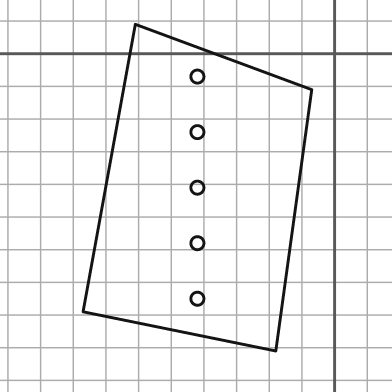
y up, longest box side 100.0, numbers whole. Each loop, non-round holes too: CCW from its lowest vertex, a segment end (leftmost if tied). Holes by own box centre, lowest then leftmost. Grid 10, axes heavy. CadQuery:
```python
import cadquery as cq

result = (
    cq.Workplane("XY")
    .moveTo(-18.0, -91.0)
    .lineTo(-7.0, -11.0)
    .lineTo(-61.0, 9.0)
    .lineTo(-77.0, -79.0)
    .close()
    .moveTo(-42.0, -75.0)
    .circle(2.0)
    .moveTo(-42.0, -58.0)
    .circle(2.0)
    .moveTo(-42.0, -41.0)
    .circle(2.0)
    .moveTo(-42.0, -24.0)
    .circle(2.0)
    .moveTo(-42.0, -7.0)
    .circle(2.0)
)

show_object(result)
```